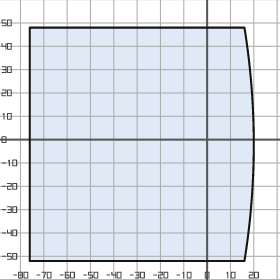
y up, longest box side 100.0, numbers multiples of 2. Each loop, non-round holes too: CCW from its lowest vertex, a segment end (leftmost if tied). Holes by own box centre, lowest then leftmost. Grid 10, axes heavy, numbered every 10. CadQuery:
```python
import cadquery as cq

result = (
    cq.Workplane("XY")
    .moveTo(-76.0, -52.0)
    .lineTo(16.0, -52.0)
    .threePointArc((20.0, -2.0), (16.0, 48.0))
    .lineTo(-76.0, 48.0)
    .close()
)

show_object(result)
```